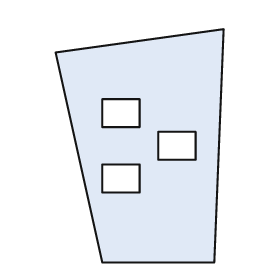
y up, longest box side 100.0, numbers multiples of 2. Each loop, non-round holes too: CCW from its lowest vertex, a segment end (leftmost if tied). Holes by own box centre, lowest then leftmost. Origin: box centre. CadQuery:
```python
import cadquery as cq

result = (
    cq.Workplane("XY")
    .moveTo(-16.0, -50.0)
    .lineTo(32.0, -50.0)
    .lineTo(36.0, 50.0)
    .lineTo(-36.0, 40.0)
    .close()
    .moveTo(-16.0, -20.0)
    .lineTo(0.0, -20.0)
    .lineTo(0.0, -8.0)
    .lineTo(-16.0, -8.0)
    .close()
    .moveTo(8.0, -6.0)
    .lineTo(24.0, -6.0)
    .lineTo(24.0, 6.0)
    .lineTo(8.0, 6.0)
    .close()
    .moveTo(-16.0, 8.0)
    .lineTo(0.0, 8.0)
    .lineTo(0.0, 20.0)
    .lineTo(-16.0, 20.0)
    .close()
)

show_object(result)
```